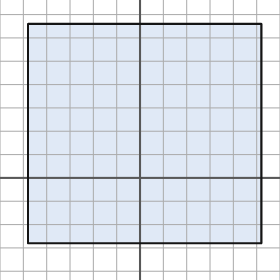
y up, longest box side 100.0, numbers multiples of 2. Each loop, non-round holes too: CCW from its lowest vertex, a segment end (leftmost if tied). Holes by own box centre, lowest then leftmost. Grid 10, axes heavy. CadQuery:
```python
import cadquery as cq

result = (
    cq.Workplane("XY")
    .moveTo(-48.0, -28.0)
    .lineTo(52.0, -28.0)
    .lineTo(52.0, 66.0)
    .lineTo(-48.0, 66.0)
    .close()
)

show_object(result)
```